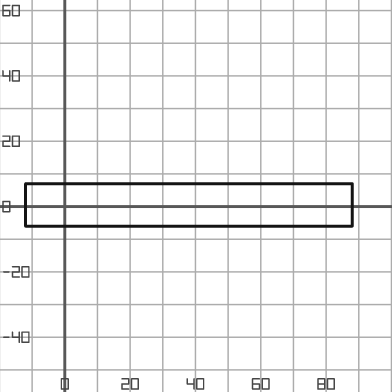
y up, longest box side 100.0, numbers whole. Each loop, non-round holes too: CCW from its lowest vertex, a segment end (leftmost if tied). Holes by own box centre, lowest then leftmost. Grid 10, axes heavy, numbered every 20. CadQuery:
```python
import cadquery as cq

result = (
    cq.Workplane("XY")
    .moveTo(-12.0, -6.0)
    .lineTo(88.0, -6.0)
    .lineTo(88.0, 7.0)
    .lineTo(-12.0, 7.0)
    .close()
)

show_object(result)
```